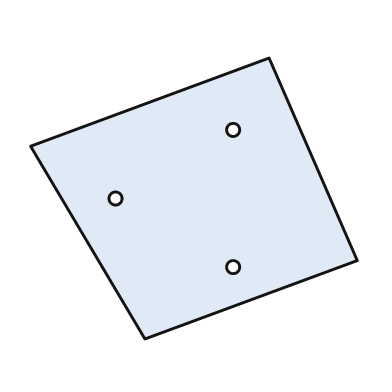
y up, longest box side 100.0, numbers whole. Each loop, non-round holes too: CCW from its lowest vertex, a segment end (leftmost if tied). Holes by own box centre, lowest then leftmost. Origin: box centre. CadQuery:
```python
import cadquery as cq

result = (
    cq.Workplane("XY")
    .moveTo(-15.0, -43.0)
    .lineTo(50.0, -19.0)
    .lineTo(23.0, 43.0)
    .lineTo(-50.0, 16.0)
    .close()
    .moveTo(12.0, -21.0)
    .circle(2.0)
    .moveTo(-24.0, 0.0)
    .circle(2.0)
    .moveTo(12.0, 21.0)
    .circle(2.0)
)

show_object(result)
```